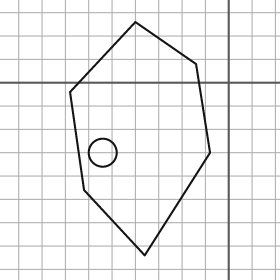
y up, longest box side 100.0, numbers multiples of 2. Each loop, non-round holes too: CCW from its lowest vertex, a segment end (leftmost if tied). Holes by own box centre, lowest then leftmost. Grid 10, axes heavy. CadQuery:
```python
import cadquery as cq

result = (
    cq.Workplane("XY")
    .moveTo(-36.0, -74.0)
    .lineTo(-8.0, -30.0)
    .lineTo(-14.0, 8.0)
    .lineTo(-40.0, 26.0)
    .lineTo(-68.0, -4.0)
    .lineTo(-62.0, -46.0)
    .close()
    .moveTo(-54.0, -30.0)
    .circle(6.0)
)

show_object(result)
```